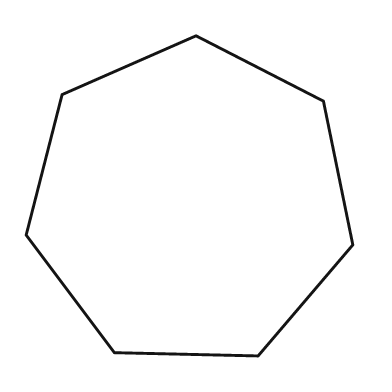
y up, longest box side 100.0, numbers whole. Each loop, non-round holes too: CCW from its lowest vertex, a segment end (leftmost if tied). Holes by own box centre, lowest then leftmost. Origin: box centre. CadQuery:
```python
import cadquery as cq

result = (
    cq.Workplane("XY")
    .moveTo(21.0, -49.0)
    .lineTo(50.0, -15.0)
    .lineTo(41.0, 29.0)
    .lineTo(2.0, 49.0)
    .lineTo(-39.0, 31.0)
    .lineTo(-50.0, -12.0)
    .lineTo(-23.0, -48.0)
    .close()
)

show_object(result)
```